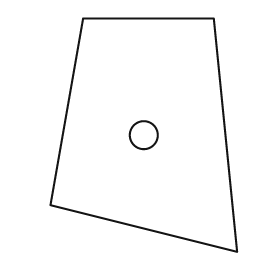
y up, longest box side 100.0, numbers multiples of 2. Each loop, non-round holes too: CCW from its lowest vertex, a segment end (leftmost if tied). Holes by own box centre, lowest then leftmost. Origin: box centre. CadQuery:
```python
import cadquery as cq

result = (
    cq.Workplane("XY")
    .moveTo(40.0, -50.0)
    .lineTo(30.0, 50.0)
    .lineTo(-26.0, 50.0)
    .lineTo(-40.0, -30.0)
    .close()
    .moveTo(0.0, 0.0)
    .circle(6.0)
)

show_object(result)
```